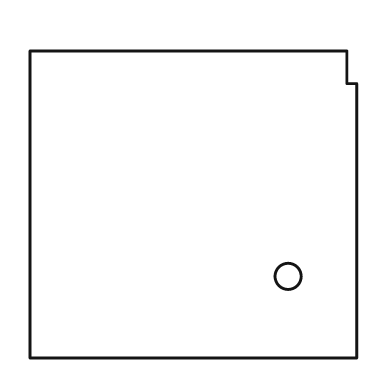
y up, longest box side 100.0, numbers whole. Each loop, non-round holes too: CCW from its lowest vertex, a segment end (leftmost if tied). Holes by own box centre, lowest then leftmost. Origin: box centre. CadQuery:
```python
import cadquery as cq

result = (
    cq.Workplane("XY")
    .moveTo(-50.0, -47.0)
    .lineTo(50.0, -47.0)
    .lineTo(50.0, 37.0)
    .lineTo(47.0, 37.0)
    .lineTo(47.0, 47.0)
    .lineTo(-50.0, 47.0)
    .close()
    .moveTo(29.0, -22.0)
    .circle(4.0)
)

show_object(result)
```